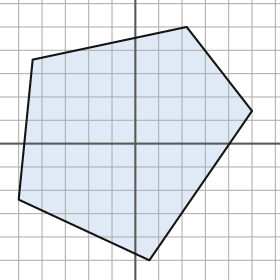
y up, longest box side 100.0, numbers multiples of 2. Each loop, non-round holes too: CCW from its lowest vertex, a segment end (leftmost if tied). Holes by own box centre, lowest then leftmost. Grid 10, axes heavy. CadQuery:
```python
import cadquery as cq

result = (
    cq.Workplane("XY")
    .moveTo(6.0, -50.0)
    .lineTo(50.0, 14.0)
    .lineTo(22.0, 50.0)
    .lineTo(-44.0, 36.0)
    .lineTo(-50.0, -24.0)
    .close()
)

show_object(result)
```